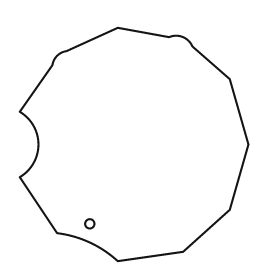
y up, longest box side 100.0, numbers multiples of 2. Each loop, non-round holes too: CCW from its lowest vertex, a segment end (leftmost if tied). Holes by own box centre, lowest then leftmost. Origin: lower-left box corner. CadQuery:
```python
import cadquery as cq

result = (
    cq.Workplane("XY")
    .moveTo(42.0, 0.0)
    .lineTo(70.0, 4.0)
    .lineTo(90.0, 22.0)
    .lineTo(98.0, 50.0)
    .lineTo(90.0, 78.0)
    .lineTo(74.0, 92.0)
    .threePointArc((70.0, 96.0), (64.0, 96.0))
    .lineTo(42.0, 100.0)
    .lineTo(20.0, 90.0)
    .threePointArc((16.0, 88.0), (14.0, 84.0))
    .lineTo(0.0, 64.0)
    .threePointArc((8.0, 50.0), (0.0, 36.0))
    .lineTo(16.0, 12.0)
    .threePointArc((30.0, 8.0), (42.0, 0.0))
    .close()
    .moveTo(30.0, 16.0)
    .circle(2.0)
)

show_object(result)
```